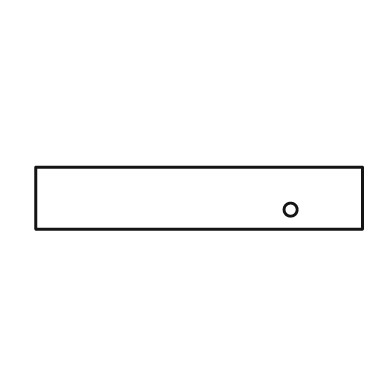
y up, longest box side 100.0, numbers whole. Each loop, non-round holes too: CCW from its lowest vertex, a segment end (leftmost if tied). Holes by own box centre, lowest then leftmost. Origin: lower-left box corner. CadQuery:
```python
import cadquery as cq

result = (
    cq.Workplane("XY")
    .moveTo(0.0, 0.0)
    .lineTo(100.0, 0.0)
    .lineTo(100.0, 19.0)
    .lineTo(0.0, 19.0)
    .close()
    .moveTo(78.0, 6.0)
    .circle(2.0)
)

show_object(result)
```